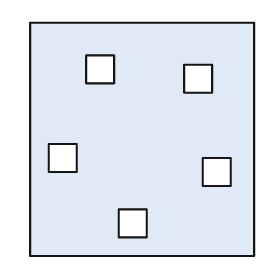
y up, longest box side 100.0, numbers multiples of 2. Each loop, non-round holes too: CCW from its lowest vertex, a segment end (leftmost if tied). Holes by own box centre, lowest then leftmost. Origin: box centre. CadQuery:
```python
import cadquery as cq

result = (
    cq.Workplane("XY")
    .moveTo(-48.0, -50.0)
    .lineTo(48.0, -50.0)
    .lineTo(48.0, 50.0)
    .lineTo(-48.0, 50.0)
    .close()
    .moveTo(-10.0, -42.0)
    .lineTo(2.0, -42.0)
    .lineTo(2.0, -30.0)
    .lineTo(-10.0, -30.0)
    .close()
    .moveTo(26.0, -20.0)
    .lineTo(38.0, -20.0)
    .lineTo(38.0, -8.0)
    .lineTo(26.0, -8.0)
    .close()
    .moveTo(-40.0, -14.0)
    .lineTo(-28.0, -14.0)
    .lineTo(-28.0, -2.0)
    .lineTo(-40.0, -2.0)
    .close()
    .moveTo(18.0, 20.0)
    .lineTo(30.0, 20.0)
    .lineTo(30.0, 32.0)
    .lineTo(18.0, 32.0)
    .close()
    .moveTo(-24.0, 24.0)
    .lineTo(-12.0, 24.0)
    .lineTo(-12.0, 36.0)
    .lineTo(-24.0, 36.0)
    .close()
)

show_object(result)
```